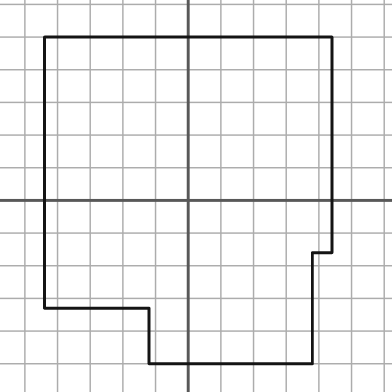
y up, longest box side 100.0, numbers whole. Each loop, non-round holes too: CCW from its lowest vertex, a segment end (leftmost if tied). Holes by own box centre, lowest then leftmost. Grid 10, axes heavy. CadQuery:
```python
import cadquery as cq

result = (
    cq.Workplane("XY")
    .moveTo(-12.0, -50.0)
    .lineTo(38.0, -50.0)
    .lineTo(38.0, -16.0)
    .lineTo(44.0, -16.0)
    .lineTo(44.0, 50.0)
    .lineTo(-44.0, 50.0)
    .lineTo(-44.0, -33.0)
    .lineTo(-12.0, -33.0)
    .close()
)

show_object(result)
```